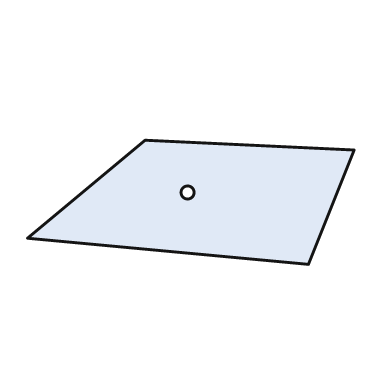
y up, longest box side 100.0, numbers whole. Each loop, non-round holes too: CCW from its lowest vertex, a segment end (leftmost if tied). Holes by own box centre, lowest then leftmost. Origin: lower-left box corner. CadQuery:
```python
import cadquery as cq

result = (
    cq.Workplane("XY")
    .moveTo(86.0, 0.0)
    .lineTo(100.0, 35.0)
    .lineTo(36.0, 38.0)
    .lineTo(0.0, 8.0)
    .close()
    .moveTo(49.0, 22.0)
    .circle(2.0)
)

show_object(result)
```